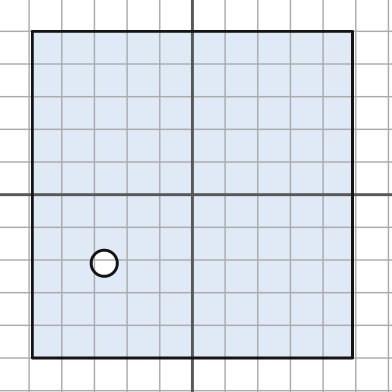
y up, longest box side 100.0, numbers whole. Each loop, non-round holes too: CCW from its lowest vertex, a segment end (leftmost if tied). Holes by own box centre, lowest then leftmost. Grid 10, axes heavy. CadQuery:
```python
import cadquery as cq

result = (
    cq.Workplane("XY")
    .moveTo(-49.0, -50.0)
    .lineTo(49.0, -50.0)
    .lineTo(49.0, 50.0)
    .lineTo(-49.0, 50.0)
    .close()
    .moveTo(-27.0, -21.0)
    .circle(4.0)
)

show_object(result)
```